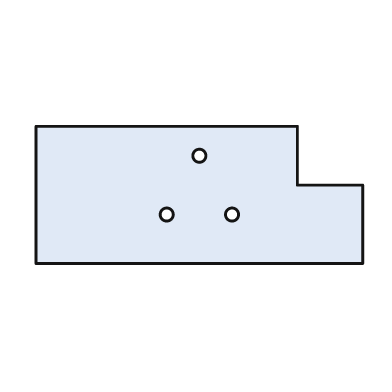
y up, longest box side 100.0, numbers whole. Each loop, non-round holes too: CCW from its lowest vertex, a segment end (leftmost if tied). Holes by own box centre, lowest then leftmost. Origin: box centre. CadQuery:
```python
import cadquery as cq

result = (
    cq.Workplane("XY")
    .moveTo(-50.0, -21.0)
    .lineTo(50.0, -21.0)
    .lineTo(50.0, 3.0)
    .lineTo(30.0, 3.0)
    .lineTo(30.0, 21.0)
    .lineTo(-50.0, 21.0)
    .close()
    .moveTo(-10.0, -6.0)
    .circle(2.0)
    .moveTo(10.0, -6.0)
    .circle(2.0)
    .moveTo(0.0, 12.0)
    .circle(2.0)
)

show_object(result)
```